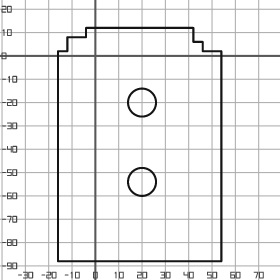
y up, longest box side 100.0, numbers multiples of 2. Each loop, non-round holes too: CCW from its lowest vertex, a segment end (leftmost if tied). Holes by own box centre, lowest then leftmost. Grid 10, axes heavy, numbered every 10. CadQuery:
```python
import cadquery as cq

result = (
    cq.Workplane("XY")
    .moveTo(-16.0, -88.0)
    .lineTo(54.0, -88.0)
    .lineTo(54.0, 2.0)
    .lineTo(46.0, 2.0)
    .lineTo(46.0, 6.0)
    .lineTo(42.0, 6.0)
    .lineTo(42.0, 12.0)
    .lineTo(-4.0, 12.0)
    .lineTo(-4.0, 8.0)
    .lineTo(-12.0, 8.0)
    .lineTo(-12.0, 2.0)
    .lineTo(-16.0, 2.0)
    .close()
    .moveTo(20.0, -54.0)
    .circle(6.0)
    .moveTo(20.0, -20.0)
    .circle(6.0)
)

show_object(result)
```